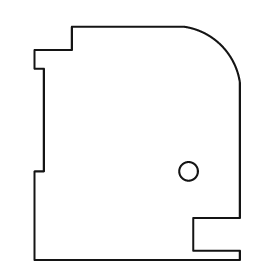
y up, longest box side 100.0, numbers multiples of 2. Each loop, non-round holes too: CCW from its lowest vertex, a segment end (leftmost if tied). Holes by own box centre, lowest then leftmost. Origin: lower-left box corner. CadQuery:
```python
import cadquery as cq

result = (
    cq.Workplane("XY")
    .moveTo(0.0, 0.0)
    .lineTo(88.0, 0.0)
    .lineTo(88.0, 4.0)
    .lineTo(68.0, 4.0)
    .lineTo(68.0, 18.0)
    .lineTo(88.0, 18.0)
    .lineTo(88.0, 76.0)
    .threePointArc((80.0, 92.0), (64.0, 100.0))
    .lineTo(16.0, 100.0)
    .lineTo(16.0, 90.0)
    .lineTo(0.0, 90.0)
    .lineTo(0.0, 82.0)
    .lineTo(4.0, 82.0)
    .lineTo(4.0, 38.0)
    .lineTo(0.0, 38.0)
    .close()
    .moveTo(66.0, 38.0)
    .circle(4.0)
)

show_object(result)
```